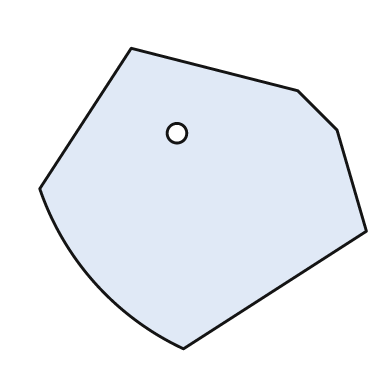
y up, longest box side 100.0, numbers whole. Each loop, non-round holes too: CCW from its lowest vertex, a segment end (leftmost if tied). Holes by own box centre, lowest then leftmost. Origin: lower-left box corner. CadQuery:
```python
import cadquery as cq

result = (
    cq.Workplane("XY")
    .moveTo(44.0, 0.0)
    .lineTo(100.0, 36.0)
    .lineTo(91.0, 67.0)
    .lineTo(79.0, 79.0)
    .lineTo(28.0, 92.0)
    .lineTo(0.0, 49.0)
    .threePointArc((17.0, 20.0), (44.0, 0.0))
    .close()
    .moveTo(42.0, 66.0)
    .circle(3.0)
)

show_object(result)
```